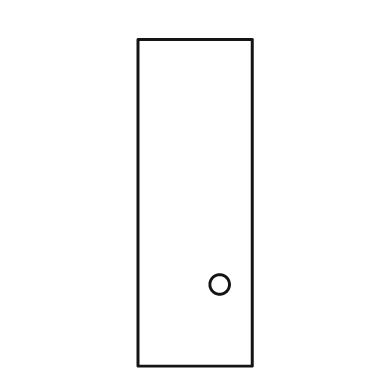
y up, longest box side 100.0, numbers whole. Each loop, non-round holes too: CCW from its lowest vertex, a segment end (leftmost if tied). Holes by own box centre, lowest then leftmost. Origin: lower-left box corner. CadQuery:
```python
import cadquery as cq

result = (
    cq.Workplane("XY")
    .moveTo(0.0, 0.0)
    .lineTo(35.0, 0.0)
    .lineTo(35.0, 100.0)
    .lineTo(0.0, 100.0)
    .close()
    .moveTo(25.0, 25.0)
    .circle(3.0)
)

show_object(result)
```